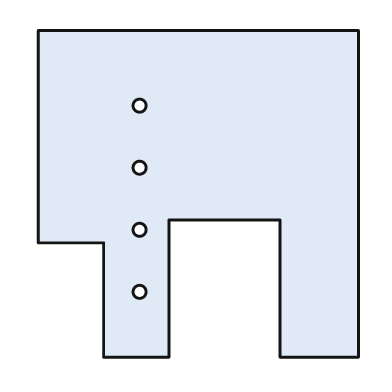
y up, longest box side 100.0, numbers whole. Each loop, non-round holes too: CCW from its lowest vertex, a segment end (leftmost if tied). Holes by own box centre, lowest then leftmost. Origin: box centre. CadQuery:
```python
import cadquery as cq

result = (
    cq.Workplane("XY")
    .moveTo(-29.0, -50.0)
    .lineTo(-9.0, -50.0)
    .lineTo(-9.0, -8.0)
    .lineTo(25.0, -8.0)
    .lineTo(25.0, -50.0)
    .lineTo(49.0, -50.0)
    .lineTo(49.0, 50.0)
    .lineTo(-49.0, 50.0)
    .lineTo(-49.0, -15.0)
    .lineTo(-29.0, -15.0)
    .close()
    .moveTo(-18.0, -30.0)
    .circle(2.0)
    .moveTo(-18.0, -11.0)
    .circle(2.0)
    .moveTo(-18.0, 8.0)
    .circle(2.0)
    .moveTo(-18.0, 27.0)
    .circle(2.0)
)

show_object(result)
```